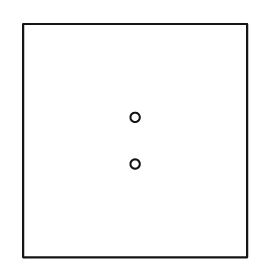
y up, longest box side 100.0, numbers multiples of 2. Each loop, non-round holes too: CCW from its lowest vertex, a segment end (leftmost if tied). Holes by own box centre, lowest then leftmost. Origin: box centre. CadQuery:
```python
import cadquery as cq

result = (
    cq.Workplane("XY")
    .moveTo(-48.0, -50.0)
    .lineTo(48.0, -50.0)
    .lineTo(48.0, 50.0)
    .lineTo(-48.0, 50.0)
    .close()
    .moveTo(0.0, -10.0)
    .circle(2.0)
    .moveTo(0.0, 10.0)
    .circle(2.0)
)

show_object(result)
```